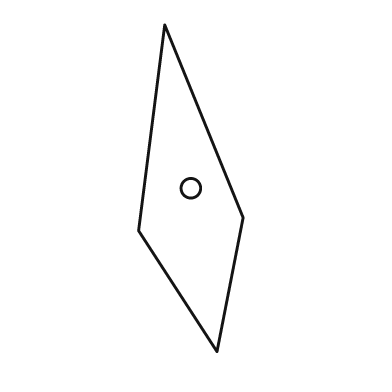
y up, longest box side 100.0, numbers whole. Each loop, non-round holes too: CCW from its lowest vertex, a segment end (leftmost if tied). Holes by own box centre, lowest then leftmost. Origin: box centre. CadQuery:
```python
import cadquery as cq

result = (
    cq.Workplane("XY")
    .moveTo(8.0, -50.0)
    .lineTo(16.0, -9.0)
    .lineTo(-8.0, 50.0)
    .lineTo(-16.0, -13.0)
    .close()
    .moveTo(0.0, 0.0)
    .circle(3.0)
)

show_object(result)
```